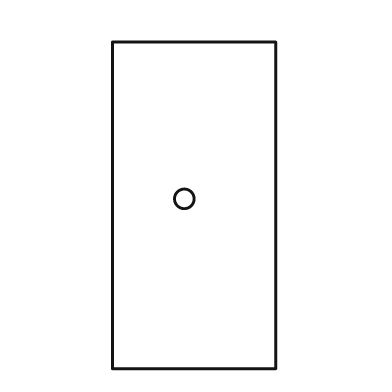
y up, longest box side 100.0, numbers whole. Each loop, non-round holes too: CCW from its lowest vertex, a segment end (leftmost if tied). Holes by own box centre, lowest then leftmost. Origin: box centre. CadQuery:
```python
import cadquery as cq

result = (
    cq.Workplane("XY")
    .moveTo(-25.0, -50.0)
    .lineTo(25.0, -50.0)
    .lineTo(25.0, 50.0)
    .lineTo(-25.0, 50.0)
    .close()
    .moveTo(-3.0, 2.0)
    .circle(3.0)
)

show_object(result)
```